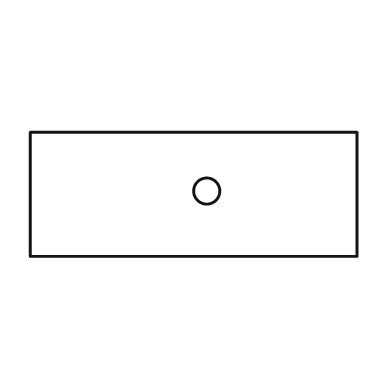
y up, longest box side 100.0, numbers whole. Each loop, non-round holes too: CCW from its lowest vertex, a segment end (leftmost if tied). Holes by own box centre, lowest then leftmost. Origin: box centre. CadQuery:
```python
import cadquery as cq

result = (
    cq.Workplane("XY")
    .moveTo(-50.0, -19.0)
    .lineTo(50.0, -19.0)
    .lineTo(50.0, 19.0)
    .lineTo(-50.0, 19.0)
    .close()
    .moveTo(4.0, 1.0)
    .circle(4.0)
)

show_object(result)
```